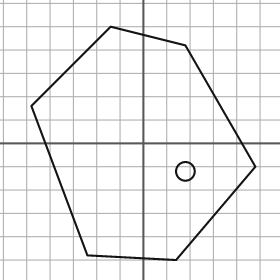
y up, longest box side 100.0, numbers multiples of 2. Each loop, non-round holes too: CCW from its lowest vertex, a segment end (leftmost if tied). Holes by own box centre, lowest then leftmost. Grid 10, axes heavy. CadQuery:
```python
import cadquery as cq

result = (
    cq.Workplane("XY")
    .moveTo(14.0, -50.0)
    .lineTo(48.0, -10.0)
    .lineTo(18.0, 42.0)
    .lineTo(-14.0, 50.0)
    .lineTo(-48.0, 16.0)
    .lineTo(-24.0, -48.0)
    .close()
    .moveTo(18.0, -12.0)
    .circle(4.0)
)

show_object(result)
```